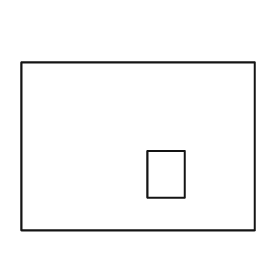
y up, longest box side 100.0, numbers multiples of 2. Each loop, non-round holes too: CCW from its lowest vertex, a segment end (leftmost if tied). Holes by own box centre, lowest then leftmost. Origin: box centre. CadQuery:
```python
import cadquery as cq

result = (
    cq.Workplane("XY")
    .moveTo(-50.0, -36.0)
    .lineTo(50.0, -36.0)
    .lineTo(50.0, 36.0)
    .lineTo(-50.0, 36.0)
    .close()
    .moveTo(4.0, -22.0)
    .lineTo(20.0, -22.0)
    .lineTo(20.0, -2.0)
    .lineTo(4.0, -2.0)
    .close()
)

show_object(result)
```